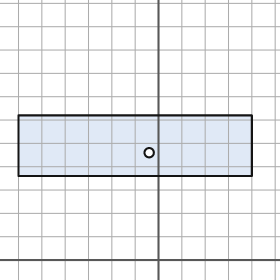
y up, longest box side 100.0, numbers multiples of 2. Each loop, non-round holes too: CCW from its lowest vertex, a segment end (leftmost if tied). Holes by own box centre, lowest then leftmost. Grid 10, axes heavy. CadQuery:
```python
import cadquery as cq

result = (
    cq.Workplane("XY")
    .moveTo(-60.0, 36.0)
    .lineTo(40.0, 36.0)
    .lineTo(40.0, 62.0)
    .lineTo(-60.0, 62.0)
    .close()
    .moveTo(-4.0, 46.0)
    .circle(2.0)
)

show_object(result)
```